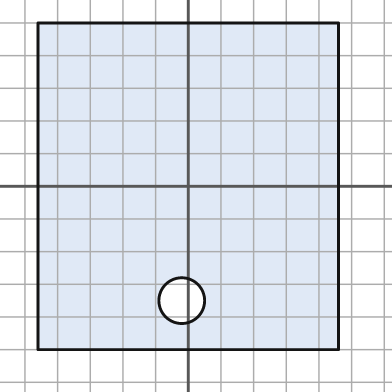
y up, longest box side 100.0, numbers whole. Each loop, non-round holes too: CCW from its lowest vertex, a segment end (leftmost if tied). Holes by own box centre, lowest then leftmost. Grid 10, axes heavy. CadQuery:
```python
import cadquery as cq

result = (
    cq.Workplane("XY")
    .moveTo(-46.0, -50.0)
    .lineTo(46.0, -50.0)
    .lineTo(46.0, 50.0)
    .lineTo(-46.0, 50.0)
    .close()
    .moveTo(-2.0, -35.0)
    .circle(7.0)
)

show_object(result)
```